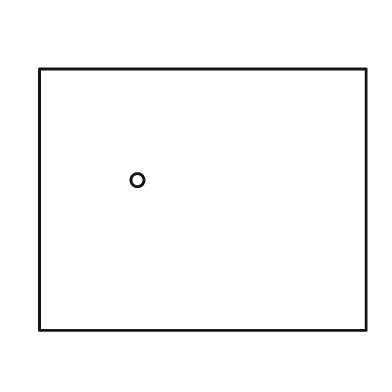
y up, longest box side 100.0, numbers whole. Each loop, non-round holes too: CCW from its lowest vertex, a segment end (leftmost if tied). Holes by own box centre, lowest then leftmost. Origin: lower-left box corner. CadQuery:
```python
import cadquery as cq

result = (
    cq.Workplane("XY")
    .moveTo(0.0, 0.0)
    .lineTo(100.0, 0.0)
    .lineTo(100.0, 80.0)
    .lineTo(0.0, 80.0)
    .close()
    .moveTo(30.0, 46.0)
    .circle(2.0)
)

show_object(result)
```